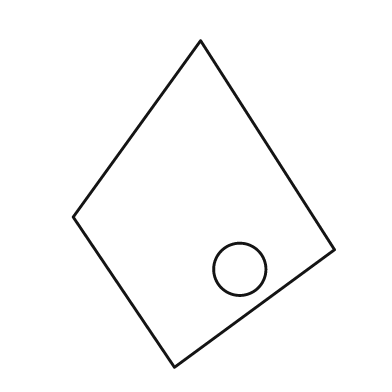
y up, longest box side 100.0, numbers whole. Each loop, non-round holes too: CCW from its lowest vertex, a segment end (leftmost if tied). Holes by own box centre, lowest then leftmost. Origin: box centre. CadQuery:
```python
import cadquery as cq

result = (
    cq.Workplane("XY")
    .moveTo(-9.0, -50.0)
    .lineTo(40.0, -14.0)
    .lineTo(-1.0, 50.0)
    .lineTo(-40.0, -4.0)
    .close()
    .moveTo(11.0, -20.0)
    .circle(8.0)
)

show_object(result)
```